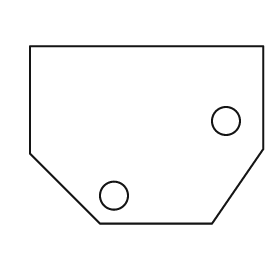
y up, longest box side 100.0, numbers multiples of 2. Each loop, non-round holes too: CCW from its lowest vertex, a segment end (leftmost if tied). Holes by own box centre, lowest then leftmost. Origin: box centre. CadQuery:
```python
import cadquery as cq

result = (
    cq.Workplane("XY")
    .moveTo(-20.0, -38.0)
    .lineTo(28.0, -38.0)
    .lineTo(50.0, -6.0)
    .lineTo(50.0, 38.0)
    .lineTo(-50.0, 38.0)
    .lineTo(-50.0, -8.0)
    .close()
    .moveTo(-14.0, -26.0)
    .circle(6.0)
    .moveTo(34.0, 6.0)
    .circle(6.0)
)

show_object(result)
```